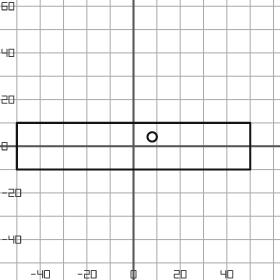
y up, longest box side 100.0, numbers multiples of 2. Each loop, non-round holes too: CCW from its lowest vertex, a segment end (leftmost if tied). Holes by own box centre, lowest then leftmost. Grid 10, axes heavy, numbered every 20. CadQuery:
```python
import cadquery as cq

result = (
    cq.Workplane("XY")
    .moveTo(-50.0, -10.0)
    .lineTo(50.0, -10.0)
    .lineTo(50.0, 10.0)
    .lineTo(-50.0, 10.0)
    .close()
    .moveTo(8.0, 4.0)
    .circle(2.0)
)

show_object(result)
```